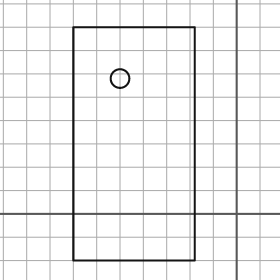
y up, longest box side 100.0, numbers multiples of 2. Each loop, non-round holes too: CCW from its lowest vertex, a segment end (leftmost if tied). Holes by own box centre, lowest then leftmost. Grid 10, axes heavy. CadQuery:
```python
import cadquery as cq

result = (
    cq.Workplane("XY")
    .moveTo(-70.0, -20.0)
    .lineTo(-18.0, -20.0)
    .lineTo(-18.0, 80.0)
    .lineTo(-70.0, 80.0)
    .close()
    .moveTo(-50.0, 58.0)
    .circle(4.0)
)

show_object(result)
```